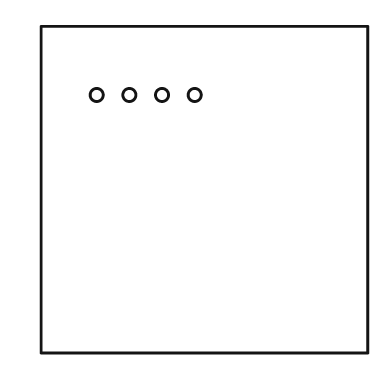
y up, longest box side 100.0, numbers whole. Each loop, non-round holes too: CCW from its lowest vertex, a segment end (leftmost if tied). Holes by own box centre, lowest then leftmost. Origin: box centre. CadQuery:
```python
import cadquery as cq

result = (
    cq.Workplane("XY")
    .moveTo(-50.0, -50.0)
    .lineTo(50.0, -50.0)
    .lineTo(50.0, 50.0)
    .lineTo(-50.0, 50.0)
    .close()
    .moveTo(-33.0, 29.0)
    .circle(2.0)
    .moveTo(-23.0, 29.0)
    .circle(2.0)
    .moveTo(-13.0, 29.0)
    .circle(2.0)
    .moveTo(-3.0, 29.0)
    .circle(2.0)
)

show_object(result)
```